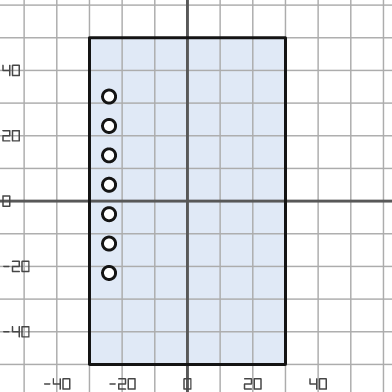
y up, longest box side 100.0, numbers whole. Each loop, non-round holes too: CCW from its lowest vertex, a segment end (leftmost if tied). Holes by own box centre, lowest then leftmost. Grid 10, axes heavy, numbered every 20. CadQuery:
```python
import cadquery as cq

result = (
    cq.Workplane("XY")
    .moveTo(-30.0, -50.0)
    .lineTo(30.0, -50.0)
    .lineTo(30.0, 50.0)
    .lineTo(-30.0, 50.0)
    .close()
    .moveTo(-24.0, -22.0)
    .circle(2.0)
    .moveTo(-24.0, -13.0)
    .circle(2.0)
    .moveTo(-24.0, -4.0)
    .circle(2.0)
    .moveTo(-24.0, 5.0)
    .circle(2.0)
    .moveTo(-24.0, 14.0)
    .circle(2.0)
    .moveTo(-24.0, 23.0)
    .circle(2.0)
    .moveTo(-24.0, 32.0)
    .circle(2.0)
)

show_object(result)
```